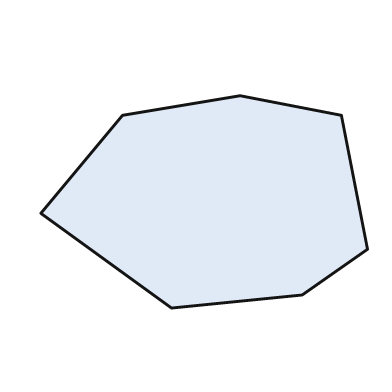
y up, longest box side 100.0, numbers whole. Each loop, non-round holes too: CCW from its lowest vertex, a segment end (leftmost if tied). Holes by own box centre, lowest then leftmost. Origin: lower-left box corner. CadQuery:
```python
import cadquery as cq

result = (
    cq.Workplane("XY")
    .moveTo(40.0, 0.0)
    .lineTo(80.0, 4.0)
    .lineTo(100.0, 18.0)
    .lineTo(92.0, 59.0)
    .lineTo(61.0, 65.0)
    .lineTo(25.0, 59.0)
    .lineTo(0.0, 29.0)
    .close()
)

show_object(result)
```